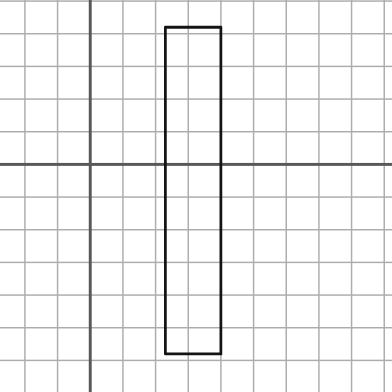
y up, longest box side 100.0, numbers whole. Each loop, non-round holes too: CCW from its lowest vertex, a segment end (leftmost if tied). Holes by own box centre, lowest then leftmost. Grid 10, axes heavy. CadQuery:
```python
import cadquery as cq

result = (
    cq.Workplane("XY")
    .moveTo(23.0, -58.0)
    .lineTo(40.0, -58.0)
    .lineTo(40.0, 42.0)
    .lineTo(23.0, 42.0)
    .close()
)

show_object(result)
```